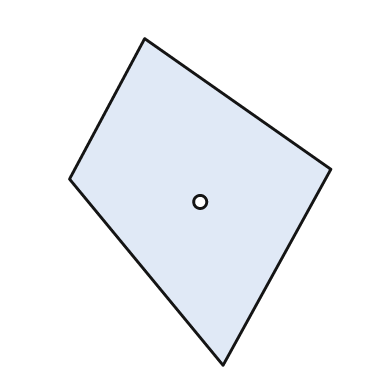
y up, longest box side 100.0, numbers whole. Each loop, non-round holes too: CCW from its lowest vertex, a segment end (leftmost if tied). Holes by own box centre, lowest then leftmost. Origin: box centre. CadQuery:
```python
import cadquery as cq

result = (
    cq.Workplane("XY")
    .moveTo(7.0, -50.0)
    .lineTo(40.0, 10.0)
    .lineTo(-17.0, 50.0)
    .lineTo(-40.0, 7.0)
    .close()
    .moveTo(0.0, 0.0)
    .circle(2.0)
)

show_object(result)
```